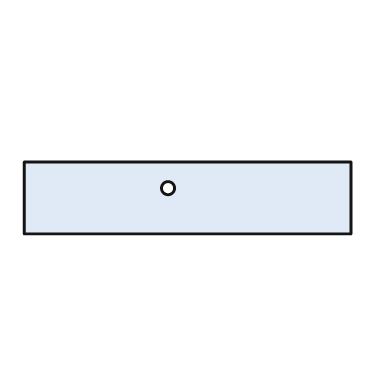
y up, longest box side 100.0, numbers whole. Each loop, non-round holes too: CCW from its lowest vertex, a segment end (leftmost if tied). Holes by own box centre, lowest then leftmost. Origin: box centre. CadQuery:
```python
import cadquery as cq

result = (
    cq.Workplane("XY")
    .moveTo(-50.0, -11.0)
    .lineTo(50.0, -11.0)
    .lineTo(50.0, 11.0)
    .lineTo(-50.0, 11.0)
    .close()
    .moveTo(-6.0, 3.0)
    .circle(2.0)
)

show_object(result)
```